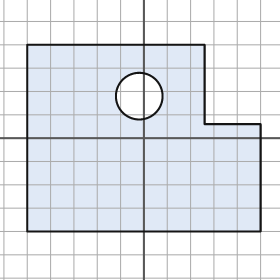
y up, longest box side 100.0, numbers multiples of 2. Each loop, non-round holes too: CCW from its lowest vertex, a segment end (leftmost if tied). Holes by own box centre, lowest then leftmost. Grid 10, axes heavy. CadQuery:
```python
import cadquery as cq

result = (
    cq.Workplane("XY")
    .moveTo(-50.0, -40.0)
    .lineTo(50.0, -40.0)
    .lineTo(50.0, 6.0)
    .lineTo(26.0, 6.0)
    .lineTo(26.0, 40.0)
    .lineTo(-50.0, 40.0)
    .close()
    .moveTo(-2.0, 18.0)
    .circle(10.0)
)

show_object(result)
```